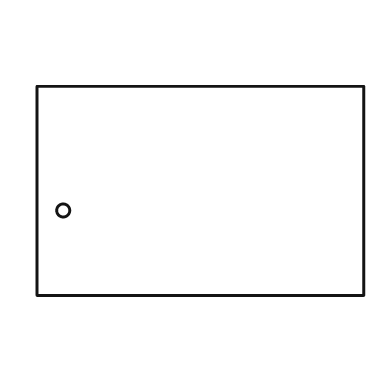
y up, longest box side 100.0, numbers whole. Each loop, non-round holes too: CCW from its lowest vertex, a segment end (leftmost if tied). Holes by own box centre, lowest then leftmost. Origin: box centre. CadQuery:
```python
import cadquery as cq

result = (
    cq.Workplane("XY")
    .moveTo(-50.0, -32.0)
    .lineTo(50.0, -32.0)
    .lineTo(50.0, 32.0)
    .lineTo(-50.0, 32.0)
    .close()
    .moveTo(-42.0, -6.0)
    .circle(2.0)
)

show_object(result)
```